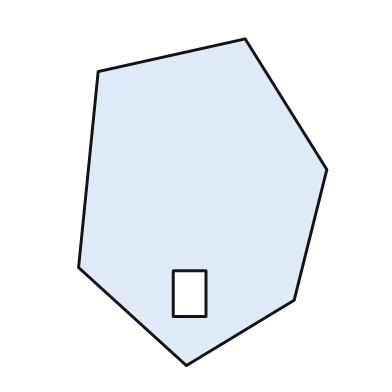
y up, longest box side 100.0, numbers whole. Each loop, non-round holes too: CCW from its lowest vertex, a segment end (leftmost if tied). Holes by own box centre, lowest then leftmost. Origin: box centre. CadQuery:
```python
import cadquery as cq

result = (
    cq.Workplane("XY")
    .moveTo(-5.0, -50.0)
    .lineTo(28.0, -30.0)
    .lineTo(38.0, 10.0)
    .lineTo(13.0, 50.0)
    .lineTo(-32.0, 40.0)
    .lineTo(-38.0, -20.0)
    .close()
    .moveTo(-9.0, -35.0)
    .lineTo(1.0, -35.0)
    .lineTo(1.0, -21.0)
    .lineTo(-9.0, -21.0)
    .close()
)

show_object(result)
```